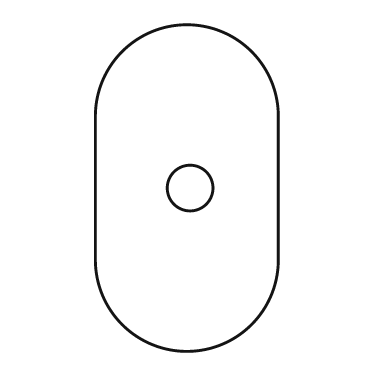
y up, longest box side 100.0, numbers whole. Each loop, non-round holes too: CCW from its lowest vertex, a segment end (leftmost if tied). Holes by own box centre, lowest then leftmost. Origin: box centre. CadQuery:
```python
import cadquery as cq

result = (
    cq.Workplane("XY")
    .moveTo(-28.0, -22.0)
    .threePointArc((0.0, -50.0), (28.0, -22.0))
    .lineTo(28.0, 22.0)
    .threePointArc((0.0, 50.0), (-28.0, 22.0))
    .close()
    .moveTo(1.0, 0.0)
    .circle(7.0)
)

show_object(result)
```